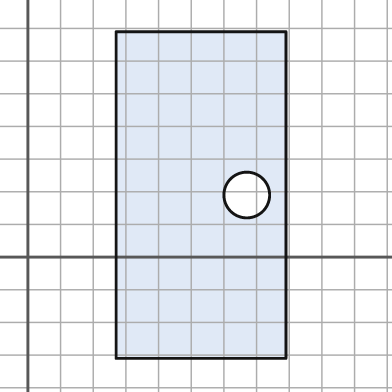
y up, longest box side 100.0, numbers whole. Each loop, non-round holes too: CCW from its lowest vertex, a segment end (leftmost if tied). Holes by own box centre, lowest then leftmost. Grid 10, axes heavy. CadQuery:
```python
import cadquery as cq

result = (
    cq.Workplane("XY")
    .moveTo(27.0, -31.0)
    .lineTo(79.0, -31.0)
    .lineTo(79.0, 69.0)
    .lineTo(27.0, 69.0)
    .close()
    .moveTo(67.0, 19.0)
    .circle(7.0)
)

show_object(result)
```